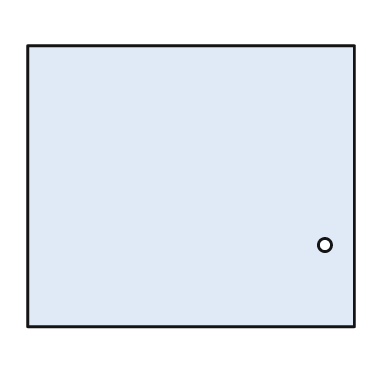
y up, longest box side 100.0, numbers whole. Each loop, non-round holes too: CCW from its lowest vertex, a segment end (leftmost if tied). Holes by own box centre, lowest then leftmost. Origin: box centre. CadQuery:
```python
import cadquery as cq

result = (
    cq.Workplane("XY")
    .moveTo(-50.0, -43.0)
    .lineTo(50.0, -43.0)
    .lineTo(50.0, 43.0)
    .lineTo(-50.0, 43.0)
    .close()
    .moveTo(41.0, -18.0)
    .circle(2.0)
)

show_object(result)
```